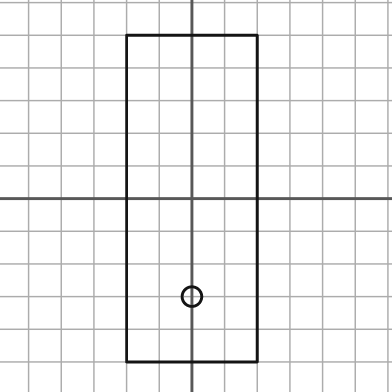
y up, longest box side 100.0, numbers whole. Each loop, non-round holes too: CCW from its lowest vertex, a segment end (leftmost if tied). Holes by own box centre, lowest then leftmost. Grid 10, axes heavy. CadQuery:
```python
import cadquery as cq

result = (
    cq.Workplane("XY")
    .moveTo(-20.0, -50.0)
    .lineTo(20.0, -50.0)
    .lineTo(20.0, 50.0)
    .lineTo(-20.0, 50.0)
    .close()
    .moveTo(0.0, -30.0)
    .circle(3.0)
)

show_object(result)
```